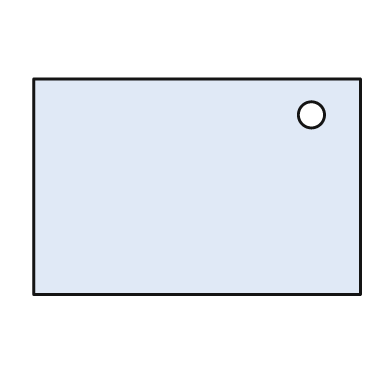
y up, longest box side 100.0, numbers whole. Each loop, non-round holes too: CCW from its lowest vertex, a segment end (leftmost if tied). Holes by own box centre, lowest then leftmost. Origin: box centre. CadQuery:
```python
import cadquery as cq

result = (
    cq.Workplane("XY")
    .moveTo(-50.0, -33.0)
    .lineTo(50.0, -33.0)
    .lineTo(50.0, 33.0)
    .lineTo(-50.0, 33.0)
    .close()
    .moveTo(35.0, 22.0)
    .circle(4.0)
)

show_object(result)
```